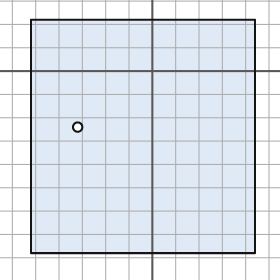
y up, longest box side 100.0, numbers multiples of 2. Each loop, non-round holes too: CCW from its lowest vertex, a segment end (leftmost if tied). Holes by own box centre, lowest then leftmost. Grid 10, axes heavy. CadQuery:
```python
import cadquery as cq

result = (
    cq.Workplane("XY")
    .moveTo(-52.0, -78.0)
    .lineTo(44.0, -78.0)
    .lineTo(44.0, 22.0)
    .lineTo(-52.0, 22.0)
    .close()
    .moveTo(-32.0, -24.0)
    .circle(2.0)
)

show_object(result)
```